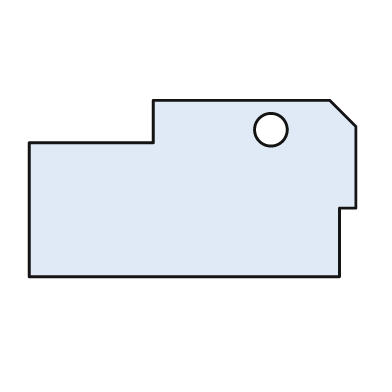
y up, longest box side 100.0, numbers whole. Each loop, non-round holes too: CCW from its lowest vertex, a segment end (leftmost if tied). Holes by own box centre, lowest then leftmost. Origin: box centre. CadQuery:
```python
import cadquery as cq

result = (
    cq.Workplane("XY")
    .moveTo(-50.0, -27.0)
    .lineTo(45.0, -27.0)
    .lineTo(45.0, -6.0)
    .lineTo(50.0, -6.0)
    .lineTo(50.0, 19.0)
    .lineTo(42.0, 27.0)
    .lineTo(-12.0, 27.0)
    .lineTo(-12.0, 14.0)
    .lineTo(-50.0, 14.0)
    .close()
    .moveTo(24.0, 18.0)
    .circle(5.0)
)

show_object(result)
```